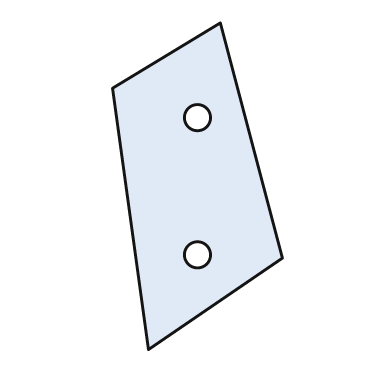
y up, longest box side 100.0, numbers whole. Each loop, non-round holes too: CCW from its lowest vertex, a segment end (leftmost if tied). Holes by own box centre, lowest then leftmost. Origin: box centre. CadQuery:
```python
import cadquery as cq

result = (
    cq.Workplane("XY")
    .moveTo(-15.0, -50.0)
    .lineTo(26.0, -22.0)
    .lineTo(7.0, 50.0)
    .lineTo(-26.0, 30.0)
    .close()
    .moveTo(0.0, -21.0)
    .circle(4.0)
    .moveTo(0.0, 21.0)
    .circle(4.0)
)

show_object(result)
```